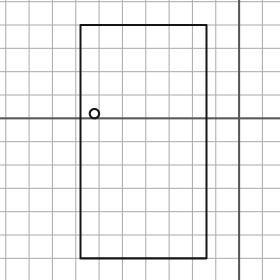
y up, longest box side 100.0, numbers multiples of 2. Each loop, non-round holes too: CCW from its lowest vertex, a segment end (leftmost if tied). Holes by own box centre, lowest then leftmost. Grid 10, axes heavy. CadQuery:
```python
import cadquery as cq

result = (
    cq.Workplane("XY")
    .moveTo(-68.0, -60.0)
    .lineTo(-14.0, -60.0)
    .lineTo(-14.0, 40.0)
    .lineTo(-68.0, 40.0)
    .close()
    .moveTo(-62.0, 2.0)
    .circle(2.0)
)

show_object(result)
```